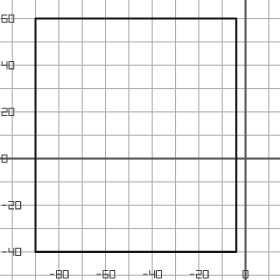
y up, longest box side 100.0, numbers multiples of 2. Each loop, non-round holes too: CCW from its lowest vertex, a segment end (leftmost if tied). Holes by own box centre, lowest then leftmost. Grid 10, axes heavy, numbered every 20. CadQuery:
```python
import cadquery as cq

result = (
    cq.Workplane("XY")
    .moveTo(-90.0, -40.0)
    .lineTo(-4.0, -40.0)
    .lineTo(-4.0, 60.0)
    .lineTo(-90.0, 60.0)
    .close()
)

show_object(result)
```